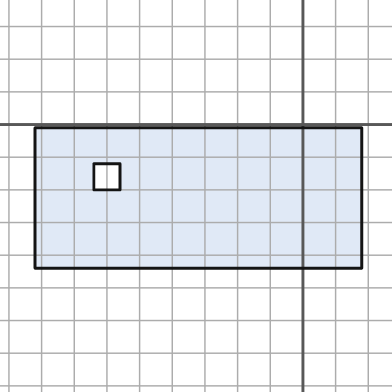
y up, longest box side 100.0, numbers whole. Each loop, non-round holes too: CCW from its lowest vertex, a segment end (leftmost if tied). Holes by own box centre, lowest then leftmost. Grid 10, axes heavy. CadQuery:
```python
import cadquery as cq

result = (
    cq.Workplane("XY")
    .moveTo(-82.0, -44.0)
    .lineTo(18.0, -44.0)
    .lineTo(18.0, -1.0)
    .lineTo(-82.0, -1.0)
    .close()
    .moveTo(-64.0, -20.0)
    .lineTo(-56.0, -20.0)
    .lineTo(-56.0, -12.0)
    .lineTo(-64.0, -12.0)
    .close()
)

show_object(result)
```